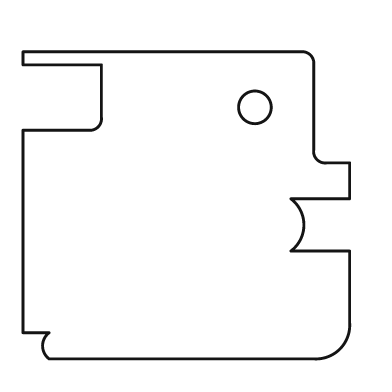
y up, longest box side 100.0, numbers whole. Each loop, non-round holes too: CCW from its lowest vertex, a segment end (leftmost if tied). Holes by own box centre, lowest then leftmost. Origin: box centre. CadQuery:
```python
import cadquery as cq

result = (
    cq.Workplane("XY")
    .moveTo(-42.0, -47.0)
    .lineTo(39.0, -47.0)
    .threePointArc((47.0, -44.0), (50.0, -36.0))
    .lineTo(50.0, -14.0)
    .lineTo(32.0, -14.0)
    .threePointArc((36.0, -6.0), (32.0, 2.0))
    .lineTo(50.0, 2.0)
    .lineTo(50.0, 13.0)
    .lineTo(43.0, 13.0)
    .threePointArc((40.0, 14.0), (39.0, 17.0))
    .lineTo(39.0, 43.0)
    .threePointArc((38.0, 46.0), (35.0, 47.0))
    .lineTo(-50.0, 47.0)
    .lineTo(-50.0, 43.0)
    .lineTo(-26.0, 43.0)
    .lineTo(-26.0, 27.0)
    .threePointArc((-27.0, 24.0), (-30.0, 23.0))
    .lineTo(-50.0, 23.0)
    .lineTo(-50.0, -39.0)
    .lineTo(-42.0, -39.0)
    .threePointArc((-44.0, -43.0), (-42.0, -47.0))
    .close()
    .moveTo(21.0, 30.0)
    .circle(5.0)
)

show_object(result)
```